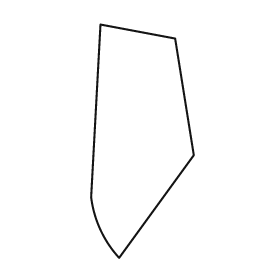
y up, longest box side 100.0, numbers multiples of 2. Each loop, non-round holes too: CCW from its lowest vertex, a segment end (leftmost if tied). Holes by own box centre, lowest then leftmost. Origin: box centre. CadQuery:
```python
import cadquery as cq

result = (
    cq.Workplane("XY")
    .moveTo(-10.0, -50.0)
    .lineTo(22.0, -6.0)
    .lineTo(14.0, 44.0)
    .lineTo(-18.0, 50.0)
    .lineTo(-22.0, -24.0)
    .threePointArc((-18.0, -38.0), (-10.0, -50.0))
    .close()
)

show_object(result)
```